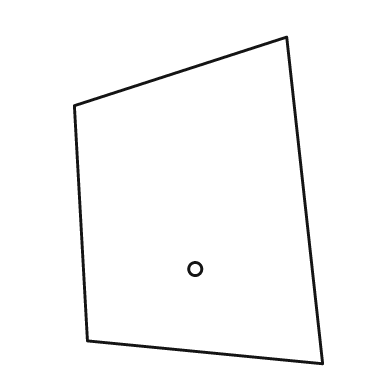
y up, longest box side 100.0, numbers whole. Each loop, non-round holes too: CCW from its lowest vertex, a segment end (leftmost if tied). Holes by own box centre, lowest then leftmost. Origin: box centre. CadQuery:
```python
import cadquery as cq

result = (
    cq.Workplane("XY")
    .moveTo(38.0, -50.0)
    .lineTo(27.0, 50.0)
    .lineTo(-38.0, 29.0)
    .lineTo(-34.0, -43.0)
    .close()
    .moveTo(-1.0, -21.0)
    .circle(2.0)
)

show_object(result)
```